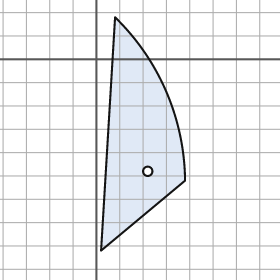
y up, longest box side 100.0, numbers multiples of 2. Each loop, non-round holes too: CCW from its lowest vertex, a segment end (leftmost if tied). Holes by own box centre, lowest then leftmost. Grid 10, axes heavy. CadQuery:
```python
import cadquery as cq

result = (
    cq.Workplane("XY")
    .moveTo(2.0, -82.0)
    .lineTo(38.0, -52.0)
    .threePointArc((30.0, -14.0), (8.0, 18.0))
    .close()
    .moveTo(22.0, -48.0)
    .circle(2.0)
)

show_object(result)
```